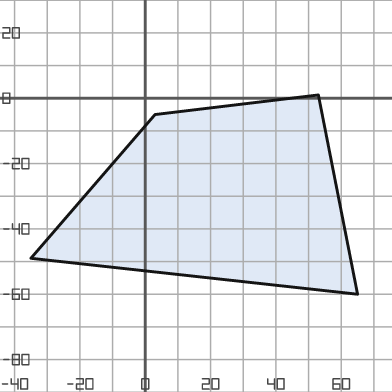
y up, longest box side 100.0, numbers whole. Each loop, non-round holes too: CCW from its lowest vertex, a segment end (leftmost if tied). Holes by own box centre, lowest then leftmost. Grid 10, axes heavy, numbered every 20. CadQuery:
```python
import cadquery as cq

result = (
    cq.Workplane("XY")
    .moveTo(65.0, -60.0)
    .lineTo(53.0, 1.0)
    .lineTo(3.0, -5.0)
    .lineTo(-35.0, -49.0)
    .close()
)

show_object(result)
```